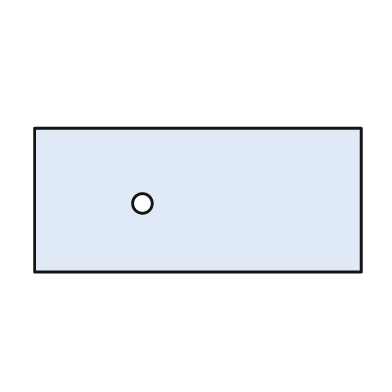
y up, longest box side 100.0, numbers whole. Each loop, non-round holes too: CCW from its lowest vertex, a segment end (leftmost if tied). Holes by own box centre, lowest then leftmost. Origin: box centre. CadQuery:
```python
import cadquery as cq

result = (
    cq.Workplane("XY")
    .moveTo(-50.0, -22.0)
    .lineTo(50.0, -22.0)
    .lineTo(50.0, 22.0)
    .lineTo(-50.0, 22.0)
    .close()
    .moveTo(-17.0, -1.0)
    .circle(3.0)
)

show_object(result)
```